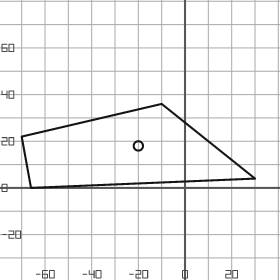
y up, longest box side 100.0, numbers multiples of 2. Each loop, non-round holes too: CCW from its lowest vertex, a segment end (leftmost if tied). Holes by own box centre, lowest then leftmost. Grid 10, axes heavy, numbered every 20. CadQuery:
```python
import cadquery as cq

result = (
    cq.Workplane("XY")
    .moveTo(-66.0, 0.0)
    .lineTo(30.0, 4.0)
    .lineTo(-10.0, 36.0)
    .lineTo(-70.0, 22.0)
    .close()
    .moveTo(-20.0, 18.0)
    .circle(2.0)
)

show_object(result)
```